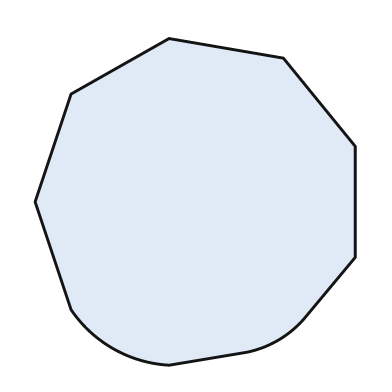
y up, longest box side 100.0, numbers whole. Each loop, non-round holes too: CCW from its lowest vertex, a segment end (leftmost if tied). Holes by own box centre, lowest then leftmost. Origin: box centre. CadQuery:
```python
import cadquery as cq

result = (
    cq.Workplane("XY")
    .moveTo(-8.0, -50.0)
    .lineTo(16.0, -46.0)
    .threePointArc((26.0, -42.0), (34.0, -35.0))
    .lineTo(49.0, -17.0)
    .lineTo(49.0, 17.0)
    .lineTo(27.0, 44.0)
    .lineTo(-8.0, 50.0)
    .lineTo(-38.0, 33.0)
    .lineTo(-49.0, 0.0)
    .lineTo(-38.0, -33.0)
    .threePointArc((-25.0, -45.0), (-8.0, -50.0))
    .close()
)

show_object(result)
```